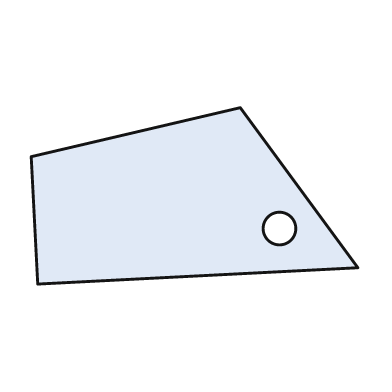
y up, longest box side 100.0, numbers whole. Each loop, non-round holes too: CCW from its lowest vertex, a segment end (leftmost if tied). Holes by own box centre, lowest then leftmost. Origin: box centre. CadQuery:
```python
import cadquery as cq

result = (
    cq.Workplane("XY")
    .moveTo(-48.0, -27.0)
    .lineTo(50.0, -22.0)
    .lineTo(14.0, 27.0)
    .lineTo(-50.0, 12.0)
    .close()
    .moveTo(26.0, -10.0)
    .circle(5.0)
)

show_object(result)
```